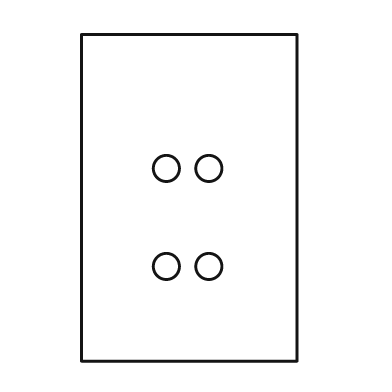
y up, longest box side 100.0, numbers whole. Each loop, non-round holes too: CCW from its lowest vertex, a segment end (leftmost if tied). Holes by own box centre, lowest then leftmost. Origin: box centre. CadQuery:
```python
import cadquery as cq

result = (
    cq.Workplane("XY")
    .moveTo(-33.0, -50.0)
    .lineTo(33.0, -50.0)
    .lineTo(33.0, 50.0)
    .lineTo(-33.0, 50.0)
    .close()
    .moveTo(-7.0, -21.0)
    .circle(4.0)
    .moveTo(6.0, -21.0)
    .circle(4.0)
    .moveTo(-7.0, 9.0)
    .circle(4.0)
    .moveTo(6.0, 9.0)
    .circle(4.0)
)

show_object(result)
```